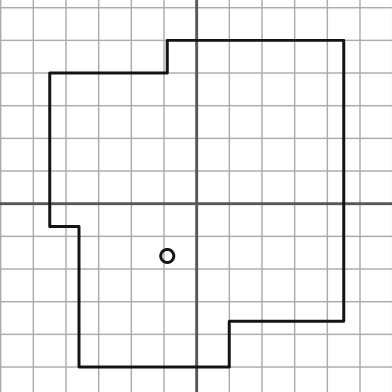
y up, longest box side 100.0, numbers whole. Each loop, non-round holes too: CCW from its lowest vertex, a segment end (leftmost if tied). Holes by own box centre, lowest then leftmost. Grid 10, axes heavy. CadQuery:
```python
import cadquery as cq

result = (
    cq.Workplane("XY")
    .moveTo(-36.0, -50.0)
    .lineTo(10.0, -50.0)
    .lineTo(10.0, -36.0)
    .lineTo(45.0, -36.0)
    .lineTo(45.0, 50.0)
    .lineTo(-9.0, 50.0)
    .lineTo(-9.0, 40.0)
    .lineTo(-45.0, 40.0)
    .lineTo(-45.0, -7.0)
    .lineTo(-36.0, -7.0)
    .close()
    .moveTo(-9.0, -16.0)
    .circle(2.0)
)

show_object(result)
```